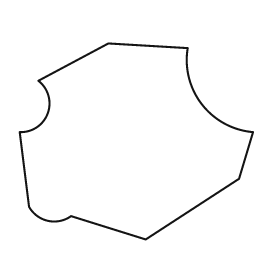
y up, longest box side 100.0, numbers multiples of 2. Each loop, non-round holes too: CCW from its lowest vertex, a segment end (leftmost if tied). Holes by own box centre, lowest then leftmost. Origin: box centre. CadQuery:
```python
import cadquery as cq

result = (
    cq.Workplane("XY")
    .moveTo(4.0, -42.0)
    .lineTo(44.0, -16.0)
    .lineTo(50.0, 4.0)
    .threePointArc((28.0, 16.0), (22.0, 40.0))
    .lineTo(-12.0, 42.0)
    .lineTo(-42.0, 26.0)
    .threePointArc((-38.0, 12.0), (-50.0, 4.0))
    .lineTo(-46.0, -28.0)
    .threePointArc((-38.0, -34.0), (-28.0, -32.0))
    .close()
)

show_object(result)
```